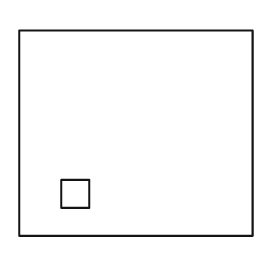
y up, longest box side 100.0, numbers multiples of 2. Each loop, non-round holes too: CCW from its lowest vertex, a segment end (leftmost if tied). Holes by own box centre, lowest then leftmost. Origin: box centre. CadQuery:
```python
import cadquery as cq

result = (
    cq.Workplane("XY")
    .moveTo(-50.0, -44.0)
    .lineTo(50.0, -44.0)
    .lineTo(50.0, 44.0)
    .lineTo(-50.0, 44.0)
    .close()
    .moveTo(-32.0, -32.0)
    .lineTo(-20.0, -32.0)
    .lineTo(-20.0, -20.0)
    .lineTo(-32.0, -20.0)
    .close()
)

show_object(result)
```